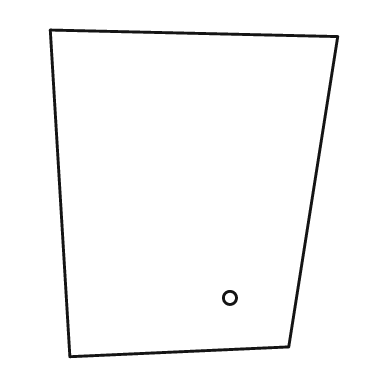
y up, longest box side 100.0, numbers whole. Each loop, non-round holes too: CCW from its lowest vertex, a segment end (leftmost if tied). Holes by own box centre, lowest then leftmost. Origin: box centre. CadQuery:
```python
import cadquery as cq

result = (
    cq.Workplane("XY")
    .moveTo(-38.0, -50.0)
    .lineTo(29.0, -47.0)
    .lineTo(44.0, 48.0)
    .lineTo(-44.0, 50.0)
    .close()
    .moveTo(11.0, -32.0)
    .circle(2.0)
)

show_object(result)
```